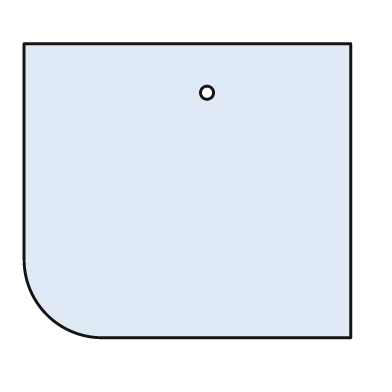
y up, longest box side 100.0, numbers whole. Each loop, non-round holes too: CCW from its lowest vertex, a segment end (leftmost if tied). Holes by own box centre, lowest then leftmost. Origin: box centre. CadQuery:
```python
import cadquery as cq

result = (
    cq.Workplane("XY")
    .moveTo(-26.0, -45.0)
    .lineTo(50.0, -45.0)
    .lineTo(50.0, 45.0)
    .lineTo(-50.0, 45.0)
    .lineTo(-50.0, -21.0)
    .threePointArc((-43.0, -38.0), (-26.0, -45.0))
    .close()
    .moveTo(6.0, 30.0)
    .circle(2.0)
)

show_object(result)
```